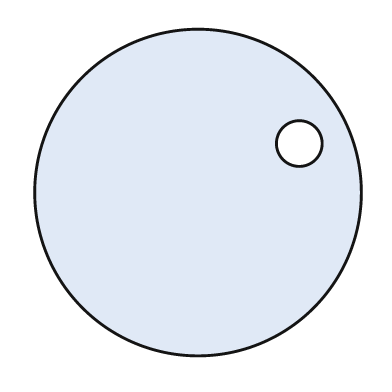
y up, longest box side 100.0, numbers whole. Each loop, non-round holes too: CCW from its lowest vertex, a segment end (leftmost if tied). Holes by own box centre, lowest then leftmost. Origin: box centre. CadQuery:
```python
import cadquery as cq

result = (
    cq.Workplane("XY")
    .moveTo(0.0, 0.0)
    .circle(50.0)
    .moveTo(31.0, 15.0)
    .circle(7.0)
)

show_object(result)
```